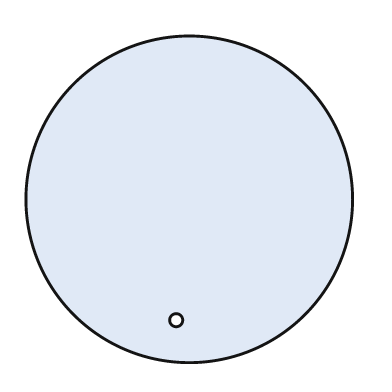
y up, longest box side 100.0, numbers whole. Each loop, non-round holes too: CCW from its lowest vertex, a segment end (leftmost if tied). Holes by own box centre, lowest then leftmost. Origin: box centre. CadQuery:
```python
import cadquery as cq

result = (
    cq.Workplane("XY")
    .moveTo(0.0, 0.0)
    .circle(50.0)
    .moveTo(-4.0, -37.0)
    .circle(2.0)
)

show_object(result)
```